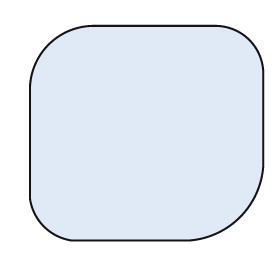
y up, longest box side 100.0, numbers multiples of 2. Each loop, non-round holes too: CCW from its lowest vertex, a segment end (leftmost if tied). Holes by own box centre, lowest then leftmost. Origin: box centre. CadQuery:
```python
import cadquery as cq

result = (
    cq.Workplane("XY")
    .moveTo(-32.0, -46.0)
    .lineTo(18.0, -46.0)
    .threePointArc((40.0, -36.0), (50.0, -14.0))
    .lineTo(50.0, 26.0)
    .threePointArc((44.0, 40.0), (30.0, 46.0))
    .lineTo(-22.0, 46.0)
    .threePointArc((-42.0, 38.0), (-50.0, 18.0))
    .lineTo(-50.0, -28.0)
    .threePointArc((-44.0, -40.0), (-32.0, -46.0))
    .close()
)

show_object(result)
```